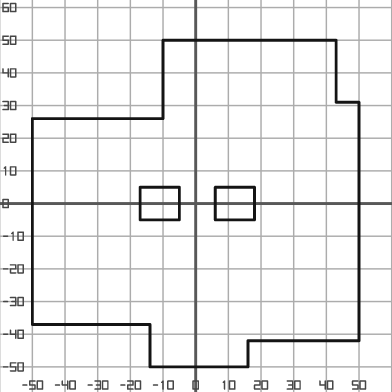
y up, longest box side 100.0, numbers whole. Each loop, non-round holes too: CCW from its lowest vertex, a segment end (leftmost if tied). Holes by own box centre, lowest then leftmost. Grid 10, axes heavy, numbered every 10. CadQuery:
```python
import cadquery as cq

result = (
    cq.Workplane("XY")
    .moveTo(-14.0, -50.0)
    .lineTo(16.0, -50.0)
    .lineTo(16.0, -42.0)
    .lineTo(50.0, -42.0)
    .lineTo(50.0, 31.0)
    .lineTo(43.0, 31.0)
    .lineTo(43.0, 50.0)
    .lineTo(-10.0, 50.0)
    .lineTo(-10.0, 26.0)
    .lineTo(-50.0, 26.0)
    .lineTo(-50.0, -37.0)
    .lineTo(-14.0, -37.0)
    .close()
    .moveTo(-17.0, -5.0)
    .lineTo(-5.0, -5.0)
    .lineTo(-5.0, 5.0)
    .lineTo(-17.0, 5.0)
    .close()
    .moveTo(6.0, -5.0)
    .lineTo(18.0, -5.0)
    .lineTo(18.0, 5.0)
    .lineTo(6.0, 5.0)
    .close()
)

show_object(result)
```